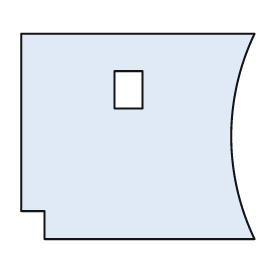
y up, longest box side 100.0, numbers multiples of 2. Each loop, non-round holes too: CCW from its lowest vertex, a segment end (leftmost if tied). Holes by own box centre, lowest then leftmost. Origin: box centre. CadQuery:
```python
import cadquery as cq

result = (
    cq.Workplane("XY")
    .moveTo(-40.0, -44.0)
    .lineTo(50.0, -44.0)
    .threePointArc((40.0, 0.0), (50.0, 44.0))
    .lineTo(-50.0, 44.0)
    .lineTo(-50.0, -32.0)
    .lineTo(-40.0, -32.0)
    .close()
    .moveTo(-10.0, 12.0)
    .lineTo(2.0, 12.0)
    .lineTo(2.0, 28.0)
    .lineTo(-10.0, 28.0)
    .close()
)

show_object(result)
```